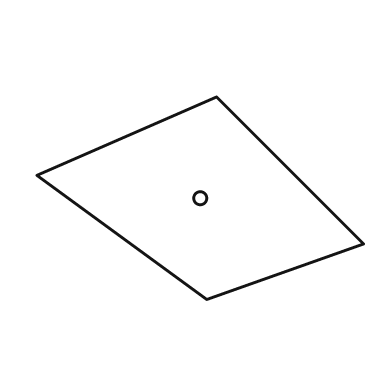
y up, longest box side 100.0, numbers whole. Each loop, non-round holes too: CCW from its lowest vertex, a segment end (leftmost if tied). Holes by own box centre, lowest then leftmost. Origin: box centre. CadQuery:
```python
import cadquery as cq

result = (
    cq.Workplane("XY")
    .moveTo(2.0, -31.0)
    .lineTo(50.0, -14.0)
    .lineTo(5.0, 31.0)
    .lineTo(-50.0, 7.0)
    .close()
    .moveTo(0.0, 0.0)
    .circle(2.0)
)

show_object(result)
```